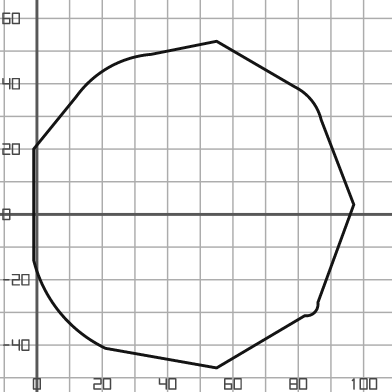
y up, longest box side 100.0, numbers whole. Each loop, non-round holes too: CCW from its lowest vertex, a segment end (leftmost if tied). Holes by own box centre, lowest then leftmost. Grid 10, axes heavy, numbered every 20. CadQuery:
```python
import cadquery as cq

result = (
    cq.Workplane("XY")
    .moveTo(55.0, -47.0)
    .lineTo(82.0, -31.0)
    .threePointArc((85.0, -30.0), (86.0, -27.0))
    .lineTo(97.0, 3.0)
    .lineTo(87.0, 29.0)
    .threePointArc((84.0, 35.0), (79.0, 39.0))
    .lineTo(55.0, 53.0)
    .lineTo(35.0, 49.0)
    .threePointArc((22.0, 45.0), (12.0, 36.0))
    .lineTo(-1.0, 20.0)
    .lineTo(-1.0, -14.0)
    .threePointArc((7.0, -30.0), (21.0, -41.0))
    .close()
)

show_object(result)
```